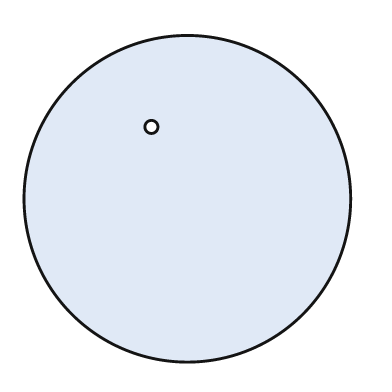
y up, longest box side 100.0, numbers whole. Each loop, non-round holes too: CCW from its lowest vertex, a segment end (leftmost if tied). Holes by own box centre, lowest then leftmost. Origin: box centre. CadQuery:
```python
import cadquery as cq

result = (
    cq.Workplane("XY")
    .moveTo(0.0, 0.0)
    .circle(50.0)
    .moveTo(-11.0, 22.0)
    .circle(2.0)
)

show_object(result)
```